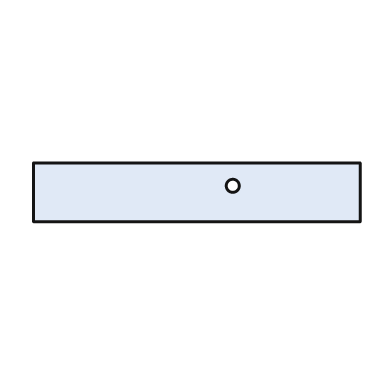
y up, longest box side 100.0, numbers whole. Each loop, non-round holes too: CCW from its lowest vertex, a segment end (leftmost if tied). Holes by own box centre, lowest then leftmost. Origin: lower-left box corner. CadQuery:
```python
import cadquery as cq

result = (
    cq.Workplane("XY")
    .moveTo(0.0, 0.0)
    .lineTo(100.0, 0.0)
    .lineTo(100.0, 18.0)
    .lineTo(0.0, 18.0)
    .close()
    .moveTo(61.0, 11.0)
    .circle(2.0)
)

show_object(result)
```